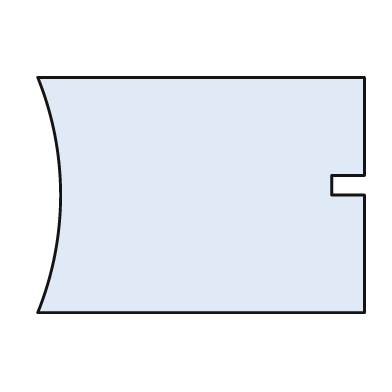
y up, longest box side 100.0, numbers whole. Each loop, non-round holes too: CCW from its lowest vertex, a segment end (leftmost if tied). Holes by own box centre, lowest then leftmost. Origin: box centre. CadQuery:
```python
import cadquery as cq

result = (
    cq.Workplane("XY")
    .moveTo(-50.0, -36.0)
    .lineTo(50.0, -36.0)
    .lineTo(50.0, 0.0)
    .lineTo(40.0, 0.0)
    .lineTo(40.0, 6.0)
    .lineTo(50.0, 6.0)
    .lineTo(50.0, 36.0)
    .lineTo(-50.0, 36.0)
    .threePointArc((-43.0, 0.0), (-50.0, -36.0))
    .close()
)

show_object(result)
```